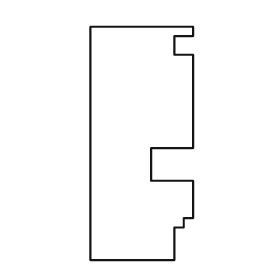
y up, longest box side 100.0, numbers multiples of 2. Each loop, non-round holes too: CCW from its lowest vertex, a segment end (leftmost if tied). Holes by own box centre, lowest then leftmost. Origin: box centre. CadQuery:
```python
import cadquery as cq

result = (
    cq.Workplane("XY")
    .moveTo(-22.0, -50.0)
    .lineTo(14.0, -50.0)
    .lineTo(14.0, -36.0)
    .lineTo(18.0, -36.0)
    .lineTo(18.0, -32.0)
    .lineTo(22.0, -32.0)
    .lineTo(22.0, -16.0)
    .lineTo(4.0, -16.0)
    .lineTo(4.0, -2.0)
    .lineTo(22.0, -2.0)
    .lineTo(22.0, 38.0)
    .lineTo(14.0, 38.0)
    .lineTo(14.0, 46.0)
    .lineTo(22.0, 46.0)
    .lineTo(22.0, 50.0)
    .lineTo(-22.0, 50.0)
    .close()
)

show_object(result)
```